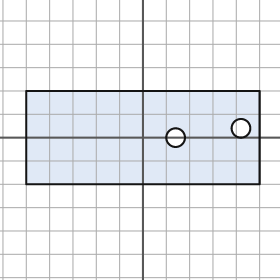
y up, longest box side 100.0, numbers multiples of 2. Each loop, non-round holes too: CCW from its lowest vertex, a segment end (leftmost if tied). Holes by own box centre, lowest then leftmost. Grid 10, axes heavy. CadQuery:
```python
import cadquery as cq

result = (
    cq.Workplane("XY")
    .moveTo(-50.0, -20.0)
    .lineTo(50.0, -20.0)
    .lineTo(50.0, 20.0)
    .lineTo(-50.0, 20.0)
    .close()
    .moveTo(14.0, 0.0)
    .circle(4.0)
    .moveTo(42.0, 4.0)
    .circle(4.0)
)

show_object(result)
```